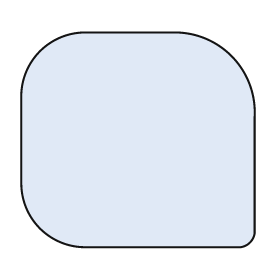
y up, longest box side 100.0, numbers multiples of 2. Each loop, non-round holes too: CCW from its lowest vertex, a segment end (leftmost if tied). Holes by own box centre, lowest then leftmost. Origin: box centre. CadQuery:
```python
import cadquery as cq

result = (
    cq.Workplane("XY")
    .moveTo(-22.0, -46.0)
    .lineTo(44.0, -46.0)
    .threePointArc((48.0, -44.0), (50.0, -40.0))
    .lineTo(50.0, 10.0)
    .threePointArc((40.0, 36.0), (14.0, 46.0))
    .lineTo(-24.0, 46.0)
    .threePointArc((-42.0, 38.0), (-50.0, 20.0))
    .lineTo(-50.0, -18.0)
    .threePointArc((-42.0, -38.0), (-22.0, -46.0))
    .close()
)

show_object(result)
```